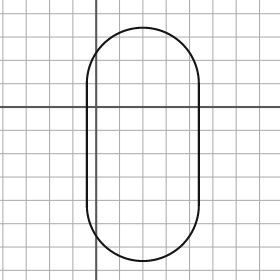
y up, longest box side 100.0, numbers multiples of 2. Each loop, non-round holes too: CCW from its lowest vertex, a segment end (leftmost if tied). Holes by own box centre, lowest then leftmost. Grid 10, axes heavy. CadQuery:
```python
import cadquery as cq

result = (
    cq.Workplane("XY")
    .moveTo(-4.0, -42.0)
    .threePointArc((20.0, -66.0), (44.0, -42.0))
    .lineTo(44.0, 10.0)
    .threePointArc((20.0, 34.0), (-4.0, 10.0))
    .close()
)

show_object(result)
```